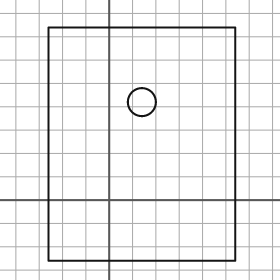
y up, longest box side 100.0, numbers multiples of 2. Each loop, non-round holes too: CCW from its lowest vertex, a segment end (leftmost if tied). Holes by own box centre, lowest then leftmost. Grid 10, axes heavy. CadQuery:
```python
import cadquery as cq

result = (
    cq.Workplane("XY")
    .moveTo(-26.0, -26.0)
    .lineTo(54.0, -26.0)
    .lineTo(54.0, 74.0)
    .lineTo(-26.0, 74.0)
    .close()
    .moveTo(14.0, 42.0)
    .circle(6.0)
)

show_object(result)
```